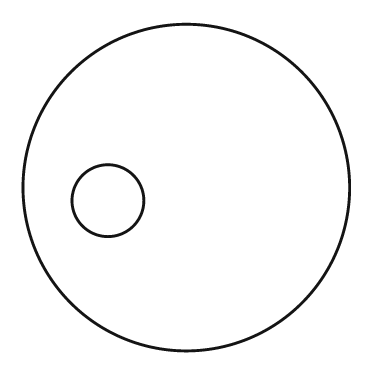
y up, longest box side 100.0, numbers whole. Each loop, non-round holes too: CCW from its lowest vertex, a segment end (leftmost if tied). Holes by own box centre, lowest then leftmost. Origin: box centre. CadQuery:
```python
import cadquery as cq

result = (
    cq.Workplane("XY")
    .moveTo(0.0, 0.0)
    .circle(50.0)
    .moveTo(-24.0, -4.0)
    .circle(11.0)
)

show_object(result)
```